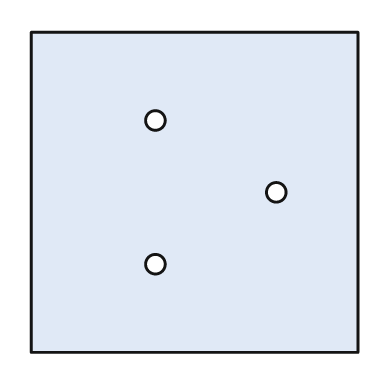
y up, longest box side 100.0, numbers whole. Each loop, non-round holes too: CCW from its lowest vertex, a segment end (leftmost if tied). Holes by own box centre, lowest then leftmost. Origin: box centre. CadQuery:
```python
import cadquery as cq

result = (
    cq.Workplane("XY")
    .moveTo(-50.0, -49.0)
    .lineTo(50.0, -49.0)
    .lineTo(50.0, 49.0)
    .lineTo(-50.0, 49.0)
    .close()
    .moveTo(-12.0, -22.0)
    .circle(3.0)
    .moveTo(25.0, 0.0)
    .circle(3.0)
    .moveTo(-12.0, 22.0)
    .circle(3.0)
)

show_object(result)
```